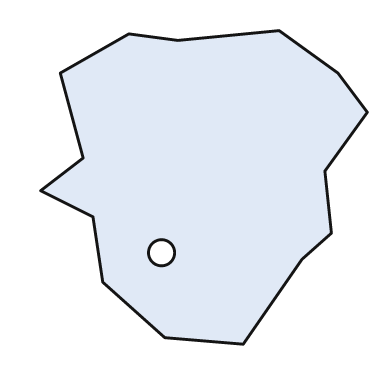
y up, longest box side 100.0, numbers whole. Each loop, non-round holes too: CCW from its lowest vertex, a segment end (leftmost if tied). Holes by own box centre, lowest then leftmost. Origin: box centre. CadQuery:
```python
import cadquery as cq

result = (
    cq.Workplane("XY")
    .moveTo(12.0, -48.0)
    .lineTo(30.0, -22.0)
    .lineTo(39.0, -14.0)
    .lineTo(37.0, 5.0)
    .lineTo(50.0, 23.0)
    .lineTo(41.0, 35.0)
    .lineTo(23.0, 48.0)
    .lineTo(-8.0, 45.0)
    .lineTo(-23.0, 47.0)
    .lineTo(-44.0, 35.0)
    .lineTo(-37.0, 9.0)
    .lineTo(-50.0, -1.0)
    .lineTo(-34.0, -9.0)
    .lineTo(-31.0, -29.0)
    .lineTo(-12.0, -46.0)
    .close()
    .moveTo(-13.0, -20.0)
    .circle(4.0)
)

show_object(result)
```